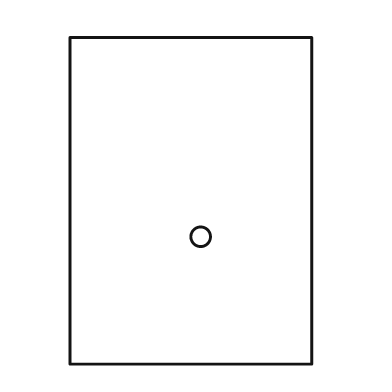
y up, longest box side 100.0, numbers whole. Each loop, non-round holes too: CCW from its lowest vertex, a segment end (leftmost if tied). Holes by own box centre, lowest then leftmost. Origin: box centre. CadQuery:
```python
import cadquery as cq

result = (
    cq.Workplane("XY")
    .moveTo(-37.0, -50.0)
    .lineTo(37.0, -50.0)
    .lineTo(37.0, 50.0)
    .lineTo(-37.0, 50.0)
    .close()
    .moveTo(3.0, -11.0)
    .circle(3.0)
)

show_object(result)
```